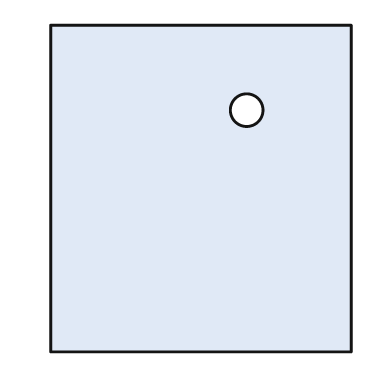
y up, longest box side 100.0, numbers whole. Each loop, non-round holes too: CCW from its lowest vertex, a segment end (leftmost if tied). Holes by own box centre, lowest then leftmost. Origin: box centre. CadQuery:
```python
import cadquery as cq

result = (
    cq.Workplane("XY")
    .moveTo(-46.0, -50.0)
    .lineTo(46.0, -50.0)
    .lineTo(46.0, 50.0)
    .lineTo(-46.0, 50.0)
    .close()
    .moveTo(14.0, 24.0)
    .circle(5.0)
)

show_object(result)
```